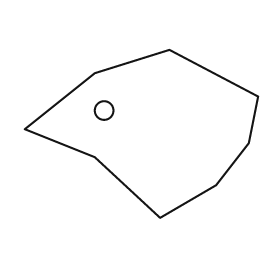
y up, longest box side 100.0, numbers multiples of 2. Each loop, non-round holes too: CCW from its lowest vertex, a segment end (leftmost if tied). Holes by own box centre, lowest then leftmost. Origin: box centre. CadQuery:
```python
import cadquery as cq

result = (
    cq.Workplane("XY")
    .moveTo(8.0, -36.0)
    .lineTo(32.0, -22.0)
    .lineTo(46.0, -4.0)
    .lineTo(50.0, 16.0)
    .lineTo(12.0, 36.0)
    .lineTo(-20.0, 26.0)
    .lineTo(-50.0, 2.0)
    .lineTo(-20.0, -10.0)
    .close()
    .moveTo(-16.0, 10.0)
    .circle(4.0)
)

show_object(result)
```